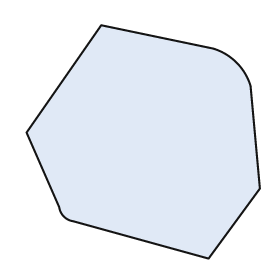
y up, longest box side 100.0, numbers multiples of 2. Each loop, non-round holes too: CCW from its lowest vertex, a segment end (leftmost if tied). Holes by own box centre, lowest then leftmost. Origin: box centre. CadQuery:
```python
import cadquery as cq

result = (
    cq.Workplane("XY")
    .moveTo(28.0, -50.0)
    .lineTo(50.0, -20.0)
    .lineTo(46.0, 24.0)
    .threePointArc((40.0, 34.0), (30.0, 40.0))
    .lineTo(-18.0, 50.0)
    .lineTo(-50.0, 4.0)
    .lineTo(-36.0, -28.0)
    .threePointArc((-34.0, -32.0), (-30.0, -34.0))
    .close()
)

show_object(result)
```